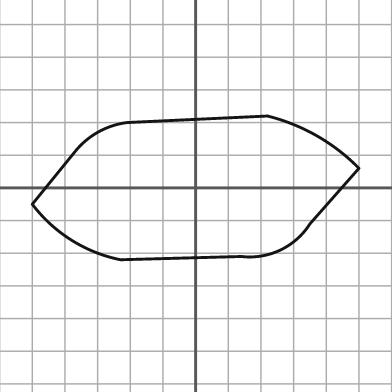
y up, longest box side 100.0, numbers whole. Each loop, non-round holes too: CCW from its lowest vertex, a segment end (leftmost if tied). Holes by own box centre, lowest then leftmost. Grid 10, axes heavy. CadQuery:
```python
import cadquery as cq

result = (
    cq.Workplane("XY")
    .moveTo(-23.0, -22.0)
    .lineTo(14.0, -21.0)
    .threePointArc((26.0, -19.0), (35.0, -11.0))
    .lineTo(50.0, 6.0)
    .threePointArc((37.0, 16.0), (22.0, 22.0))
    .lineTo(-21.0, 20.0)
    .threePointArc((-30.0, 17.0), (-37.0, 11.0))
    .lineTo(-50.0, -5.0)
    .threePointArc((-38.0, -16.0), (-23.0, -22.0))
    .close()
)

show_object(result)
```